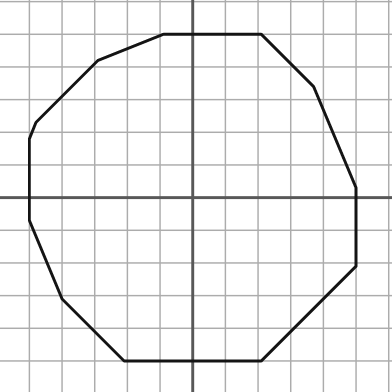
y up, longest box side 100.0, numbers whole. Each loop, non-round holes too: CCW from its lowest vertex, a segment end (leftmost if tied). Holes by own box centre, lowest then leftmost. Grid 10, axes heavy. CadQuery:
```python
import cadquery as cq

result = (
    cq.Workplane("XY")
    .moveTo(-21.0, -50.0)
    .lineTo(21.0, -50.0)
    .lineTo(50.0, -21.0)
    .lineTo(50.0, 3.0)
    .lineTo(37.0, 34.0)
    .lineTo(21.0, 50.0)
    .lineTo(-9.0, 50.0)
    .lineTo(-29.0, 42.0)
    .lineTo(-48.0, 23.0)
    .lineTo(-50.0, 18.0)
    .lineTo(-50.0, -7.0)
    .lineTo(-40.0, -31.0)
    .close()
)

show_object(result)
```